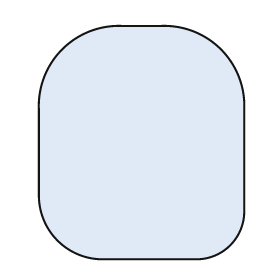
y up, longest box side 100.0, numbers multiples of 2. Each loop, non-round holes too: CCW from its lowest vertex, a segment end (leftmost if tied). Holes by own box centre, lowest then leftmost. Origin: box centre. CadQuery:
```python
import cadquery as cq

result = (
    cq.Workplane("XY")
    .moveTo(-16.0, -50.0)
    .lineTo(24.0, -50.0)
    .threePointArc((38.0, -44.0), (44.0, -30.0))
    .lineTo(44.0, 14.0)
    .threePointArc((34.0, 40.0), (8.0, 50.0))
    .lineTo(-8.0, 50.0)
    .threePointArc((-34.0, 40.0), (-44.0, 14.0))
    .lineTo(-44.0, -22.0)
    .threePointArc((-36.0, -42.0), (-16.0, -50.0))
    .close()
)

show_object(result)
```